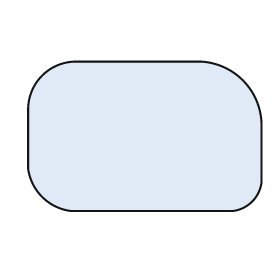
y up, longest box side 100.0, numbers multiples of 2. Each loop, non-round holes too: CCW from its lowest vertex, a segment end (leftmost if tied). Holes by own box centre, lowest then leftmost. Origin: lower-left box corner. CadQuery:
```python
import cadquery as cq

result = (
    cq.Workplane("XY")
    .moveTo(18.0, 0.0)
    .lineTo(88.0, 0.0)
    .threePointArc((96.0, 4.0), (100.0, 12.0))
    .lineTo(100.0, 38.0)
    .threePointArc((92.0, 56.0), (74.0, 64.0))
    .lineTo(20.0, 64.0)
    .threePointArc((6.0, 58.0), (0.0, 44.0))
    .lineTo(0.0, 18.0)
    .threePointArc((6.0, 6.0), (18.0, 0.0))
    .close()
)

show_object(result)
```